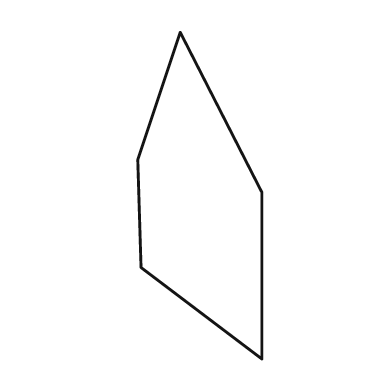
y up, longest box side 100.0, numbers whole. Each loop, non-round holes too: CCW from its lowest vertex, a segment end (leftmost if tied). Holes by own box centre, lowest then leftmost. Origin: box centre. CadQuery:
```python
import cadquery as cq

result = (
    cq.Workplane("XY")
    .moveTo(19.0, -50.0)
    .lineTo(19.0, 1.0)
    .lineTo(-6.0, 50.0)
    .lineTo(-19.0, 11.0)
    .lineTo(-18.0, -22.0)
    .close()
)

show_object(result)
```